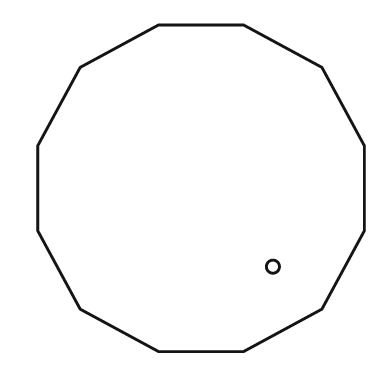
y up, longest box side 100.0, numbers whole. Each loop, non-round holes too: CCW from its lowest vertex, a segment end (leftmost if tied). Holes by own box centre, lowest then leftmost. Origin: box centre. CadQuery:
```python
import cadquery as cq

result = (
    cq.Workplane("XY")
    .moveTo(-13.0, -50.0)
    .lineTo(13.0, -50.0)
    .lineTo(37.0, -37.0)
    .lineTo(50.0, -13.0)
    .lineTo(50.0, 13.0)
    .lineTo(37.0, 37.0)
    .lineTo(13.0, 50.0)
    .lineTo(-13.0, 50.0)
    .lineTo(-37.0, 37.0)
    .lineTo(-50.0, 13.0)
    .lineTo(-50.0, -13.0)
    .lineTo(-37.0, -37.0)
    .close()
    .moveTo(22.0, -24.0)
    .circle(2.0)
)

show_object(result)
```